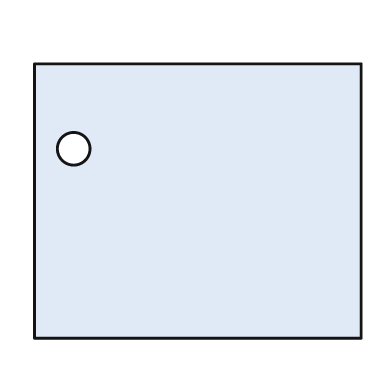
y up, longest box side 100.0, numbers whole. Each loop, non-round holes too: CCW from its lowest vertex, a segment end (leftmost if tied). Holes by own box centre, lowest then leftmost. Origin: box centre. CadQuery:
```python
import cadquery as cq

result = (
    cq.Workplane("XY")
    .moveTo(-50.0, -42.0)
    .lineTo(50.0, -42.0)
    .lineTo(50.0, 42.0)
    .lineTo(-50.0, 42.0)
    .close()
    .moveTo(-38.0, 16.0)
    .circle(5.0)
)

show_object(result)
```